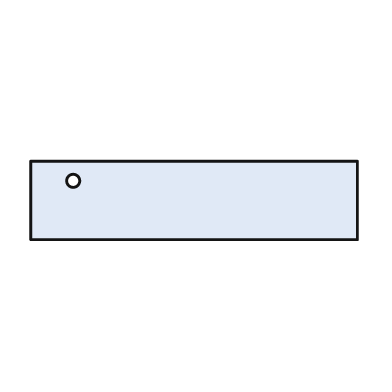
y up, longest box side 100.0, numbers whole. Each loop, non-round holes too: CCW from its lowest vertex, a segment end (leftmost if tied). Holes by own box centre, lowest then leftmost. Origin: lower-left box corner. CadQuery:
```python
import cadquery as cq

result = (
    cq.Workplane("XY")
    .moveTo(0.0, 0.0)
    .lineTo(100.0, 0.0)
    .lineTo(100.0, 24.0)
    .lineTo(0.0, 24.0)
    .close()
    .moveTo(13.0, 18.0)
    .circle(2.0)
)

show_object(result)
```